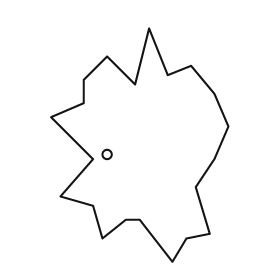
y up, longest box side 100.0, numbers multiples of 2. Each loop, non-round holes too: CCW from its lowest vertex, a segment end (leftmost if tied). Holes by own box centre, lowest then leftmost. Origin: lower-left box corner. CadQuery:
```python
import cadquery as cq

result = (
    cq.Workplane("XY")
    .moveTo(52.0, 0.0)
    .lineTo(58.0, 10.0)
    .lineTo(68.0, 12.0)
    .lineTo(62.0, 32.0)
    .lineTo(70.0, 44.0)
    .lineTo(76.0, 58.0)
    .lineTo(70.0, 72.0)
    .lineTo(60.0, 84.0)
    .lineTo(50.0, 80.0)
    .lineTo(42.0, 100.0)
    .lineTo(36.0, 76.0)
    .lineTo(24.0, 88.0)
    .lineTo(14.0, 78.0)
    .lineTo(14.0, 68.0)
    .lineTo(0.0, 62.0)
    .lineTo(18.0, 44.0)
    .lineTo(4.0, 28.0)
    .lineTo(18.0, 24.0)
    .lineTo(22.0, 10.0)
    .lineTo(32.0, 18.0)
    .lineTo(38.0, 18.0)
    .close()
    .moveTo(24.0, 46.0)
    .circle(2.0)
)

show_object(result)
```